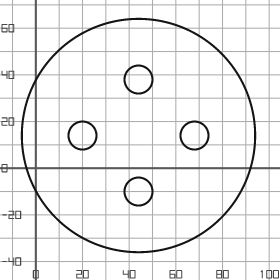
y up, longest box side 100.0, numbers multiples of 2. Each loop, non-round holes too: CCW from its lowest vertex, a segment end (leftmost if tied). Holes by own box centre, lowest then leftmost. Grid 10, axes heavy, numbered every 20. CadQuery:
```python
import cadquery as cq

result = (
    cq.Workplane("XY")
    .moveTo(44.0, 14.0)
    .circle(50.0)
    .moveTo(44.0, -10.0)
    .circle(6.0)
    .moveTo(20.0, 14.0)
    .circle(6.0)
    .moveTo(68.0, 14.0)
    .circle(6.0)
    .moveTo(44.0, 38.0)
    .circle(6.0)
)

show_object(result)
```